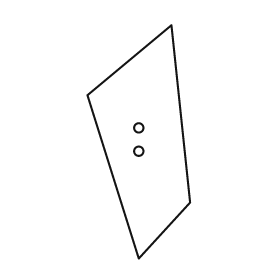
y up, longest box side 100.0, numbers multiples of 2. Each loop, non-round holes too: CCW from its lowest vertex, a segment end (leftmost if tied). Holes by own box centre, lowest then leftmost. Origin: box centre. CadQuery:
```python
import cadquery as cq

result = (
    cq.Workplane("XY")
    .moveTo(0.0, -50.0)
    .lineTo(22.0, -26.0)
    .lineTo(14.0, 50.0)
    .lineTo(-22.0, 20.0)
    .close()
    .moveTo(0.0, -4.0)
    .circle(2.0)
    .moveTo(0.0, 6.0)
    .circle(2.0)
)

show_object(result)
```